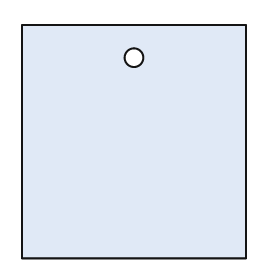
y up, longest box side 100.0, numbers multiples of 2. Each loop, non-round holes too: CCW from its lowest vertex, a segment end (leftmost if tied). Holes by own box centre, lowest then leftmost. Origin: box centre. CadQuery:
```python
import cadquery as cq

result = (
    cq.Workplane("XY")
    .moveTo(-48.0, -50.0)
    .lineTo(48.0, -50.0)
    .lineTo(48.0, 50.0)
    .lineTo(-48.0, 50.0)
    .close()
    .moveTo(0.0, 36.0)
    .circle(4.0)
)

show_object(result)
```